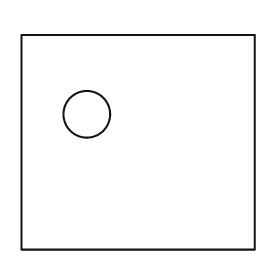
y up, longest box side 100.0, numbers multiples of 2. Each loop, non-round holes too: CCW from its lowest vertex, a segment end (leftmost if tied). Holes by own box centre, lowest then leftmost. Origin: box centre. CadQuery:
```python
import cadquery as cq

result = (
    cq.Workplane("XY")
    .moveTo(-50.0, -46.0)
    .lineTo(50.0, -46.0)
    .lineTo(50.0, 46.0)
    .lineTo(-50.0, 46.0)
    .close()
    .moveTo(-22.0, 12.0)
    .circle(10.0)
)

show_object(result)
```